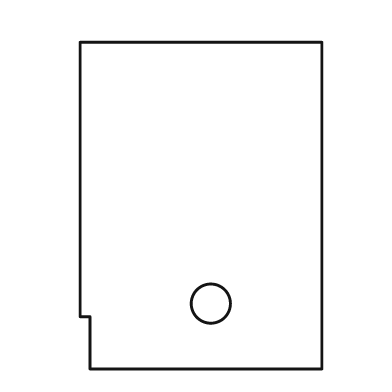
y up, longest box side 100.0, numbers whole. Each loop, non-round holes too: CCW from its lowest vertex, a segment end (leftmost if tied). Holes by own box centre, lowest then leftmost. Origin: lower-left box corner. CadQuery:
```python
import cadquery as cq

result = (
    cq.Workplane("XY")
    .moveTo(3.0, 0.0)
    .lineTo(74.0, 0.0)
    .lineTo(74.0, 100.0)
    .lineTo(0.0, 100.0)
    .lineTo(0.0, 16.0)
    .lineTo(3.0, 16.0)
    .close()
    .moveTo(40.0, 20.0)
    .circle(6.0)
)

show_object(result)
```